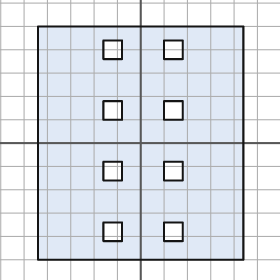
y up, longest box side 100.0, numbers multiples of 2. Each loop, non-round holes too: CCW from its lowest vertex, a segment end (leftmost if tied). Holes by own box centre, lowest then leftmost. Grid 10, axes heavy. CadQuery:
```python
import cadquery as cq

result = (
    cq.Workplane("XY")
    .moveTo(-44.0, -50.0)
    .lineTo(44.0, -50.0)
    .lineTo(44.0, 50.0)
    .lineTo(-44.0, 50.0)
    .close()
    .moveTo(-16.0, -42.0)
    .lineTo(-8.0, -42.0)
    .lineTo(-8.0, -34.0)
    .lineTo(-16.0, -34.0)
    .close()
    .moveTo(10.0, -42.0)
    .lineTo(18.0, -42.0)
    .lineTo(18.0, -34.0)
    .lineTo(10.0, -34.0)
    .close()
    .moveTo(-16.0, -16.0)
    .lineTo(-8.0, -16.0)
    .lineTo(-8.0, -8.0)
    .lineTo(-16.0, -8.0)
    .close()
    .moveTo(10.0, -16.0)
    .lineTo(18.0, -16.0)
    .lineTo(18.0, -8.0)
    .lineTo(10.0, -8.0)
    .close()
    .moveTo(-16.0, 10.0)
    .lineTo(-8.0, 10.0)
    .lineTo(-8.0, 18.0)
    .lineTo(-16.0, 18.0)
    .close()
    .moveTo(10.0, 10.0)
    .lineTo(18.0, 10.0)
    .lineTo(18.0, 18.0)
    .lineTo(10.0, 18.0)
    .close()
    .moveTo(-16.0, 36.0)
    .lineTo(-8.0, 36.0)
    .lineTo(-8.0, 44.0)
    .lineTo(-16.0, 44.0)
    .close()
    .moveTo(10.0, 36.0)
    .lineTo(18.0, 36.0)
    .lineTo(18.0, 44.0)
    .lineTo(10.0, 44.0)
    .close()
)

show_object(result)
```